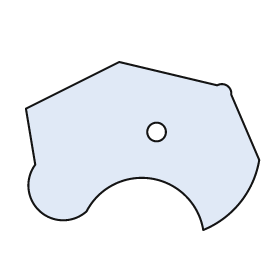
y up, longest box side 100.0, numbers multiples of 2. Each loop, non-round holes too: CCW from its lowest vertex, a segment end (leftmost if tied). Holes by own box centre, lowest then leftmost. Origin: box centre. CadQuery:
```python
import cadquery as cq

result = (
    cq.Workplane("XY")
    .moveTo(26.0, -36.0)
    .threePointArc((42.0, -24.0), (50.0, -6.0))
    .lineTo(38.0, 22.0)
    .threePointArc((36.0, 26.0), (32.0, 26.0))
    .lineTo(-10.0, 36.0)
    .lineTo(-50.0, 16.0)
    .lineTo(-46.0, -8.0)
    .threePointArc((-44.0, -28.0), (-24.0, -28.0))
    .threePointArc((4.0, -14.0), (26.0, -36.0))
    .close()
    .moveTo(6.0, 6.0)
    .circle(4.0)
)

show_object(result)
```